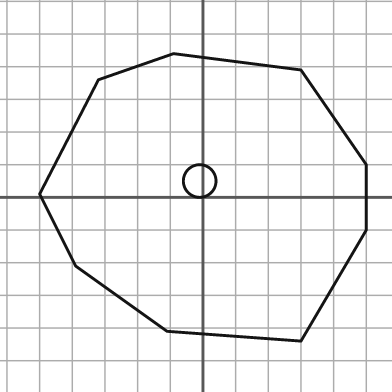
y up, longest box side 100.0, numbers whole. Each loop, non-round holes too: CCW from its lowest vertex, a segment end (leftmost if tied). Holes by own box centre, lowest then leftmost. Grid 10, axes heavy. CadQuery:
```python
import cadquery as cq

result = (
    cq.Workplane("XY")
    .moveTo(30.0, -44.0)
    .lineTo(50.0, -10.0)
    .lineTo(50.0, 10.0)
    .lineTo(30.0, 39.0)
    .lineTo(-9.0, 44.0)
    .lineTo(-32.0, 36.0)
    .lineTo(-50.0, 1.0)
    .lineTo(-39.0, -21.0)
    .lineTo(-11.0, -41.0)
    .close()
    .moveTo(-1.0, 5.0)
    .circle(5.0)
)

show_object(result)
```